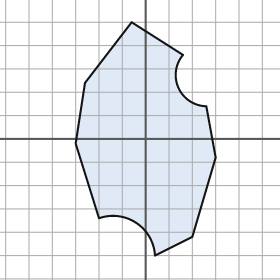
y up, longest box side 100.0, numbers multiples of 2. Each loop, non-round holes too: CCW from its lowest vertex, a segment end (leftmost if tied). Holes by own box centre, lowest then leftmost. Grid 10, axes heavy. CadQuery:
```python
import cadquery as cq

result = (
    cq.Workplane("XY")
    .moveTo(4.0, -50.0)
    .lineTo(20.0, -42.0)
    .lineTo(30.0, -8.0)
    .lineTo(26.0, 14.0)
    .threePointArc((14.0, 22.0), (16.0, 36.0))
    .lineTo(-6.0, 50.0)
    .lineTo(-26.0, 24.0)
    .lineTo(-30.0, -2.0)
    .lineTo(-20.0, -34.0)
    .threePointArc((-4.0, -36.0), (4.0, -50.0))
    .close()
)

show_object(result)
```